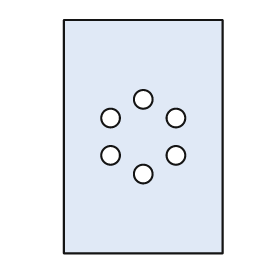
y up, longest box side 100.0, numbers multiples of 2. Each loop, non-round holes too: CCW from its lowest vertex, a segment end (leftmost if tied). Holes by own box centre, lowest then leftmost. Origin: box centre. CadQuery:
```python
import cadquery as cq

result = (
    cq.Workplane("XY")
    .moveTo(-34.0, -50.0)
    .lineTo(34.0, -50.0)
    .lineTo(34.0, 50.0)
    .lineTo(-34.0, 50.0)
    .close()
    .moveTo(0.0, -16.0)
    .circle(4.0)
    .moveTo(-14.0, -8.0)
    .circle(4.0)
    .moveTo(14.0, -8.0)
    .circle(4.0)
    .moveTo(-14.0, 8.0)
    .circle(4.0)
    .moveTo(14.0, 8.0)
    .circle(4.0)
    .moveTo(0.0, 16.0)
    .circle(4.0)
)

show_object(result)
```